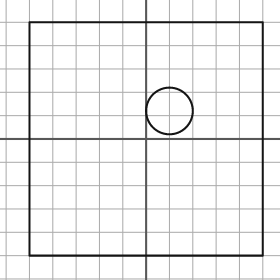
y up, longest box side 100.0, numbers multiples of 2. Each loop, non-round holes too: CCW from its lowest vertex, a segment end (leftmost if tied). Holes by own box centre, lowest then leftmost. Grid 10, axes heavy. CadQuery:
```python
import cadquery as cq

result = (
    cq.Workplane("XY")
    .moveTo(-50.0, -50.0)
    .lineTo(50.0, -50.0)
    .lineTo(50.0, 50.0)
    .lineTo(-50.0, 50.0)
    .close()
    .moveTo(10.0, 12.0)
    .circle(10.0)
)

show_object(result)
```